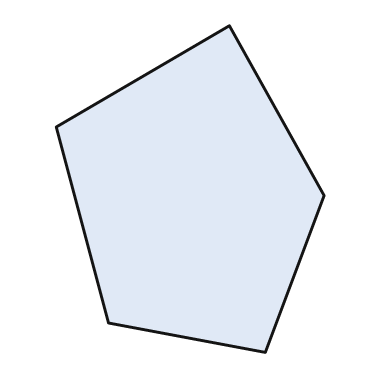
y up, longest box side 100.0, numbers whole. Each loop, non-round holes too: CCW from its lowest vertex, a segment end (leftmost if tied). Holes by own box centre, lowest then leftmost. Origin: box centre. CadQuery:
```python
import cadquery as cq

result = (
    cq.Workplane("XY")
    .moveTo(23.0, -50.0)
    .lineTo(41.0, -2.0)
    .lineTo(12.0, 50.0)
    .lineTo(-41.0, 19.0)
    .lineTo(-25.0, -41.0)
    .close()
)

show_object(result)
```